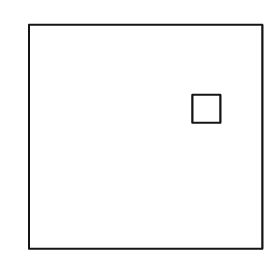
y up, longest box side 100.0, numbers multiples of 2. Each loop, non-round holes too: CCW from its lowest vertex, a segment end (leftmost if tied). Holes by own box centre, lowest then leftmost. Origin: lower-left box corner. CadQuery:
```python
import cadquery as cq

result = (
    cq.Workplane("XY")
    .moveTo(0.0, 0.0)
    .lineTo(100.0, 0.0)
    .lineTo(100.0, 96.0)
    .lineTo(0.0, 96.0)
    .close()
    .moveTo(70.0, 54.0)
    .lineTo(82.0, 54.0)
    .lineTo(82.0, 66.0)
    .lineTo(70.0, 66.0)
    .close()
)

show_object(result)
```